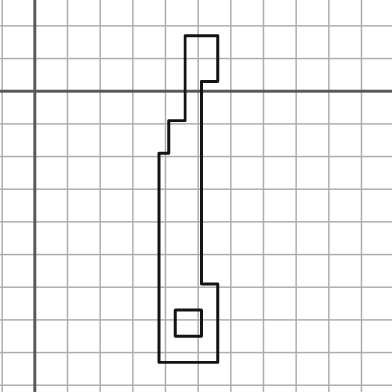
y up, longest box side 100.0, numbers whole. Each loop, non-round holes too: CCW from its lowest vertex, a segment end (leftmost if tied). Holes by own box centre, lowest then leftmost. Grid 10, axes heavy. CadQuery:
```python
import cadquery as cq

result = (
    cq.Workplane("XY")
    .moveTo(38.0, -83.0)
    .lineTo(56.0, -83.0)
    .lineTo(56.0, -59.0)
    .lineTo(51.0, -59.0)
    .lineTo(51.0, 3.0)
    .lineTo(56.0, 3.0)
    .lineTo(56.0, 17.0)
    .lineTo(46.0, 17.0)
    .lineTo(46.0, -9.0)
    .lineTo(41.0, -9.0)
    .lineTo(41.0, -19.0)
    .lineTo(38.0, -19.0)
    .close()
    .moveTo(43.0, -75.0)
    .lineTo(51.0, -75.0)
    .lineTo(51.0, -67.0)
    .lineTo(43.0, -67.0)
    .close()
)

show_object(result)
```